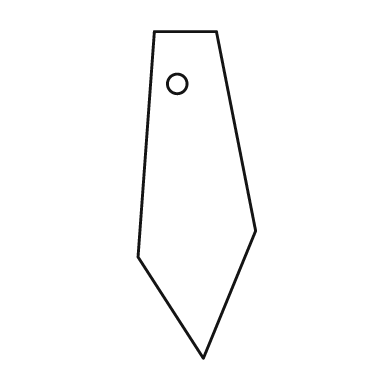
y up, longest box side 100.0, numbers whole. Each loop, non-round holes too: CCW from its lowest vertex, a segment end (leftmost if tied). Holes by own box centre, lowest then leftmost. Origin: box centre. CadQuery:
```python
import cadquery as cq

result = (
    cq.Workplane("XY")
    .moveTo(2.0, -50.0)
    .lineTo(18.0, -11.0)
    .lineTo(6.0, 50.0)
    .lineTo(-13.0, 50.0)
    .lineTo(-18.0, -19.0)
    .close()
    .moveTo(-6.0, 34.0)
    .circle(3.0)
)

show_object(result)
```